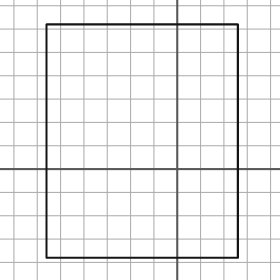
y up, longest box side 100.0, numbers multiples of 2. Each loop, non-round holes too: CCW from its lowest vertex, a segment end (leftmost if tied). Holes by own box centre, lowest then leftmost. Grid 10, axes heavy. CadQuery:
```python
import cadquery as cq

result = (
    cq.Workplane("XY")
    .moveTo(-56.0, -38.0)
    .lineTo(26.0, -38.0)
    .lineTo(26.0, 62.0)
    .lineTo(-56.0, 62.0)
    .close()
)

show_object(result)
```